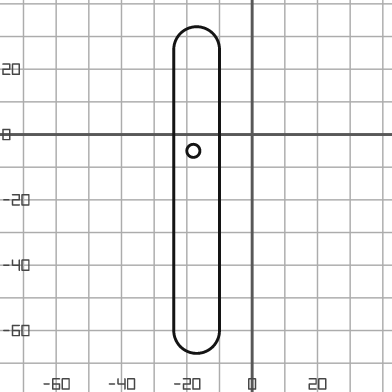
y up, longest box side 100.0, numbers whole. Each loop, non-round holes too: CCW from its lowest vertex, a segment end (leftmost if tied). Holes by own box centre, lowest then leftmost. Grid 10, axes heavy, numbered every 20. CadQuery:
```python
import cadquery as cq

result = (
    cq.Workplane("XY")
    .moveTo(-24.0, -60.0)
    .threePointArc((-17.0, -67.0), (-10.0, -60.0))
    .lineTo(-10.0, 26.0)
    .threePointArc((-17.0, 33.0), (-24.0, 26.0))
    .close()
    .moveTo(-18.0, -5.0)
    .circle(2.0)
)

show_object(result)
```